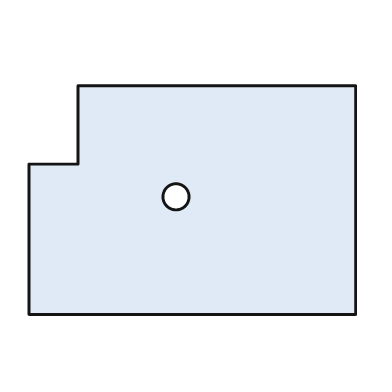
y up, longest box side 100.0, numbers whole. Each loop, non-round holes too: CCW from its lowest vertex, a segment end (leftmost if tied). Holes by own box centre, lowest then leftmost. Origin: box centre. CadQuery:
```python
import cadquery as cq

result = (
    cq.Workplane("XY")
    .moveTo(-50.0, -35.0)
    .lineTo(50.0, -35.0)
    .lineTo(50.0, 35.0)
    .lineTo(-35.0, 35.0)
    .lineTo(-35.0, 11.0)
    .lineTo(-50.0, 11.0)
    .close()
    .moveTo(-5.0, 1.0)
    .circle(4.0)
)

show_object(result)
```